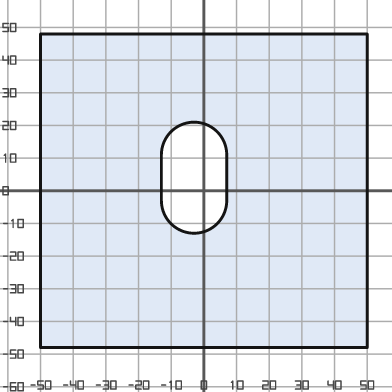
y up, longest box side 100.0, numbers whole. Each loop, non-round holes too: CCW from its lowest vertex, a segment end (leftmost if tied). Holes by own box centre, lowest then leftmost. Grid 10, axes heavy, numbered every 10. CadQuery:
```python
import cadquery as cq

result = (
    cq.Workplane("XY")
    .moveTo(-50.0, -48.0)
    .lineTo(50.0, -48.0)
    .lineTo(50.0, 48.0)
    .lineTo(-50.0, 48.0)
    .close()
    .moveTo(-13.0, -3.0)
    .threePointArc((-3.0, -13.0), (7.0, -3.0))
    .lineTo(7.0, 11.0)
    .threePointArc((-3.0, 21.0), (-13.0, 11.0))
    .close()
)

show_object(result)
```